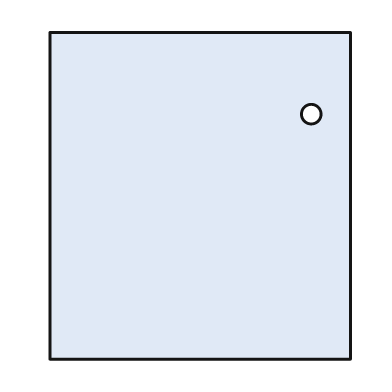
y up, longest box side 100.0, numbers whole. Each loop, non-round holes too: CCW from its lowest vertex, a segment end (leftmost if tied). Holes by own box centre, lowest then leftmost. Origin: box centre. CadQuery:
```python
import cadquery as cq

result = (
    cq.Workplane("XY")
    .moveTo(-46.0, -50.0)
    .lineTo(46.0, -50.0)
    .lineTo(46.0, 50.0)
    .lineTo(-46.0, 50.0)
    .close()
    .moveTo(34.0, 25.0)
    .circle(3.0)
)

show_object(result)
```